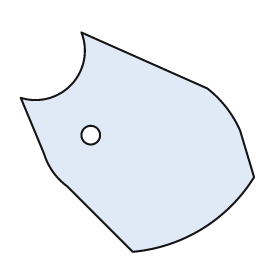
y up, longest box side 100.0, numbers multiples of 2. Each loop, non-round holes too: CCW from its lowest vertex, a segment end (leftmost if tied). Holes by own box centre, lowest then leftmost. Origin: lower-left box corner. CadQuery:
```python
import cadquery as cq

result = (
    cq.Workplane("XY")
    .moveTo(48.0, 0.0)
    .threePointArc((78.0, 10.0), (100.0, 32.0))
    .lineTo(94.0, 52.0)
    .threePointArc((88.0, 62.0), (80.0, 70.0))
    .lineTo(26.0, 94.0)
    .threePointArc((22.0, 72.0), (0.0, 66.0))
    .lineTo(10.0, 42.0)
    .threePointArc((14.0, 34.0), (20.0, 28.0))
    .close()
    .moveTo(30.0, 50.0)
    .circle(4.0)
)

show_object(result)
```